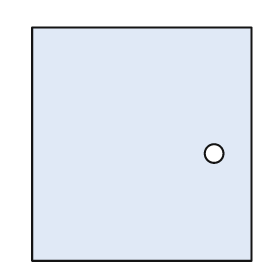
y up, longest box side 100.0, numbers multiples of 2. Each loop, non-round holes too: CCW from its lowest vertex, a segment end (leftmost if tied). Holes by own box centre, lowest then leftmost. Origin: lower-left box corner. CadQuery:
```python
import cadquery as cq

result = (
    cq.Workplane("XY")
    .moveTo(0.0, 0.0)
    .lineTo(94.0, 0.0)
    .lineTo(94.0, 100.0)
    .lineTo(0.0, 100.0)
    .close()
    .moveTo(78.0, 46.0)
    .circle(4.0)
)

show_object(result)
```